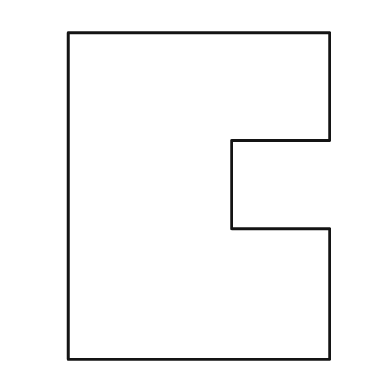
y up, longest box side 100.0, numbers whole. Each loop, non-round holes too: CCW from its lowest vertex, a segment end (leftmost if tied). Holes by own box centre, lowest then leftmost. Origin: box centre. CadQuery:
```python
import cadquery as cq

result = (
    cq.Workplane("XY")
    .moveTo(-40.0, -50.0)
    .lineTo(40.0, -50.0)
    .lineTo(40.0, -10.0)
    .lineTo(10.0, -10.0)
    .lineTo(10.0, 17.0)
    .lineTo(40.0, 17.0)
    .lineTo(40.0, 50.0)
    .lineTo(-40.0, 50.0)
    .close()
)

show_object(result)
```